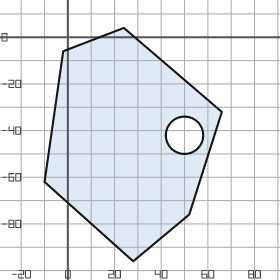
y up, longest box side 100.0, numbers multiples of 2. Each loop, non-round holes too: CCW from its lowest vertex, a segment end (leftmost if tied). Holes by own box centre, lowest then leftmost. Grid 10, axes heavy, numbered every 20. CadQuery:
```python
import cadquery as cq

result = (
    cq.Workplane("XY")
    .moveTo(28.0, -96.0)
    .lineTo(52.0, -76.0)
    .lineTo(66.0, -32.0)
    .lineTo(24.0, 4.0)
    .lineTo(-2.0, -6.0)
    .lineTo(-10.0, -62.0)
    .close()
    .moveTo(50.0, -42.0)
    .circle(8.0)
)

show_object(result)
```